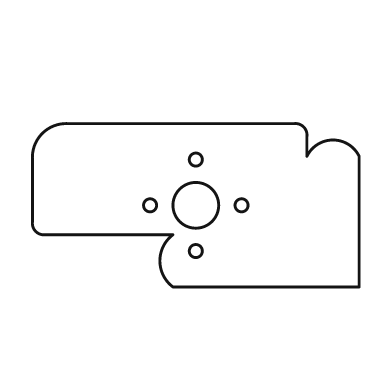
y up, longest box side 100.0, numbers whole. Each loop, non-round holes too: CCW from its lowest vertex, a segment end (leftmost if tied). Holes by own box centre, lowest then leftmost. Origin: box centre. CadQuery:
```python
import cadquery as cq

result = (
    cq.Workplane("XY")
    .moveTo(-7.0, -25.0)
    .lineTo(50.0, -25.0)
    .lineTo(50.0, 15.0)
    .threePointArc((42.0, 20.0), (34.0, 15.0))
    .lineTo(34.0, 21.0)
    .threePointArc((33.0, 24.0), (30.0, 25.0))
    .lineTo(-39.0, 25.0)
    .threePointArc((-47.0, 22.0), (-50.0, 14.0))
    .lineTo(-50.0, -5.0)
    .threePointArc((-49.0, -8.0), (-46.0, -9.0))
    .lineTo(-7.0, -9.0)
    .threePointArc((-11.0, -17.0), (-7.0, -25.0))
    .close()
    .moveTo(0.0, -14.0)
    .circle(2.0)
    .moveTo(-14.0, 0.0)
    .circle(2.0)
    .moveTo(0.0, 0.0)
    .circle(7.0)
    .moveTo(14.0, 0.0)
    .circle(2.0)
    .moveTo(0.0, 14.0)
    .circle(2.0)
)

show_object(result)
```